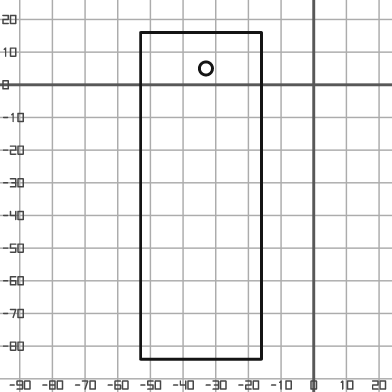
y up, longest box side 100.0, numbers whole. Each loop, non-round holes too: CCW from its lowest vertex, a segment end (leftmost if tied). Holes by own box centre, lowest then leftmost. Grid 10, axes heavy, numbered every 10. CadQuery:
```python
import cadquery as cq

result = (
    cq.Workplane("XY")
    .moveTo(-53.0, -84.0)
    .lineTo(-16.0, -84.0)
    .lineTo(-16.0, 16.0)
    .lineTo(-53.0, 16.0)
    .close()
    .moveTo(-33.0, 5.0)
    .circle(2.0)
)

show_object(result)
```